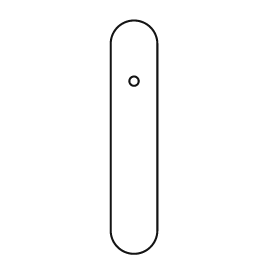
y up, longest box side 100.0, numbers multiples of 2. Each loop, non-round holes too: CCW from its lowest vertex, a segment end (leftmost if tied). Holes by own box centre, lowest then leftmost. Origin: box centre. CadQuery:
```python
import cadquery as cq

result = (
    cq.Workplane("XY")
    .moveTo(-10.0, -40.0)
    .threePointArc((0.0, -50.0), (10.0, -40.0))
    .lineTo(10.0, 40.0)
    .threePointArc((0.0, 50.0), (-10.0, 40.0))
    .close()
    .moveTo(0.0, 24.0)
    .circle(2.0)
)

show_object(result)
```